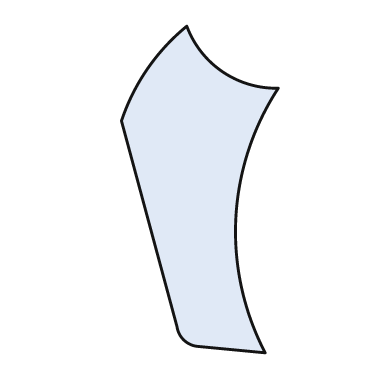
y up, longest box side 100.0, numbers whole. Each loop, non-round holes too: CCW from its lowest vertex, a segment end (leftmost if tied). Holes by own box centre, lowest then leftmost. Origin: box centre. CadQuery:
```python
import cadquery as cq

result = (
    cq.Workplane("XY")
    .moveTo(20.0, -50.0)
    .threePointArc((11.0, -9.0), (24.0, 31.0))
    .threePointArc((7.0, 36.0), (-4.0, 50.0))
    .threePointArc((-16.0, 37.0), (-24.0, 21.0))
    .lineTo(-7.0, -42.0)
    .threePointArc((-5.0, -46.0), (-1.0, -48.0))
    .close()
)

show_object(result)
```